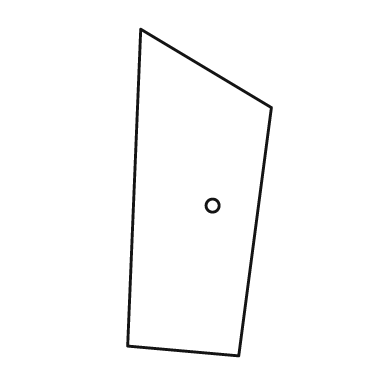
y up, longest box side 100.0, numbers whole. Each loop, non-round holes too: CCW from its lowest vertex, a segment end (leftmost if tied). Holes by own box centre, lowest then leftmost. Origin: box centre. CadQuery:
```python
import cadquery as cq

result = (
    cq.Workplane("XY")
    .moveTo(12.0, -50.0)
    .lineTo(22.0, 26.0)
    .lineTo(-18.0, 50.0)
    .lineTo(-22.0, -47.0)
    .close()
    .moveTo(4.0, -4.0)
    .circle(2.0)
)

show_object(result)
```